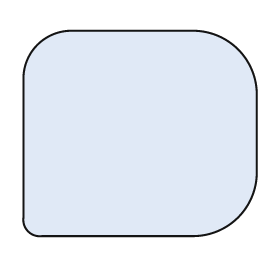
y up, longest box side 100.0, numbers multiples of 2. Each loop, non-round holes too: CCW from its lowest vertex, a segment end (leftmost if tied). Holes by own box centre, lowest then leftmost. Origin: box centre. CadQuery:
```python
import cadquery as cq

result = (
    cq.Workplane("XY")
    .moveTo(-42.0, -44.0)
    .lineTo(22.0, -44.0)
    .threePointArc((42.0, -36.0), (50.0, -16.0))
    .lineTo(50.0, 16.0)
    .threePointArc((42.0, 36.0), (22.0, 44.0))
    .lineTo(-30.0, 44.0)
    .threePointArc((-44.0, 38.0), (-50.0, 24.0))
    .lineTo(-50.0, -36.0)
    .threePointArc((-48.0, -42.0), (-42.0, -44.0))
    .close()
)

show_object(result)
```